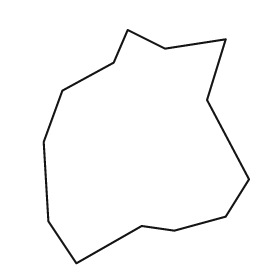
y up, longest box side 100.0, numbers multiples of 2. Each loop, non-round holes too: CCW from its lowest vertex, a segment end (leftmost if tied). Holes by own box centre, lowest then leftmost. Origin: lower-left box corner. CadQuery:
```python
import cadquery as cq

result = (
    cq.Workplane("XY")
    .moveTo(14.0, 0.0)
    .lineTo(42.0, 16.0)
    .lineTo(56.0, 14.0)
    .lineTo(78.0, 20.0)
    .lineTo(88.0, 36.0)
    .lineTo(70.0, 70.0)
    .lineTo(78.0, 96.0)
    .lineTo(52.0, 92.0)
    .lineTo(36.0, 100.0)
    .lineTo(30.0, 86.0)
    .lineTo(8.0, 74.0)
    .lineTo(0.0, 52.0)
    .lineTo(2.0, 18.0)
    .close()
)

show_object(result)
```